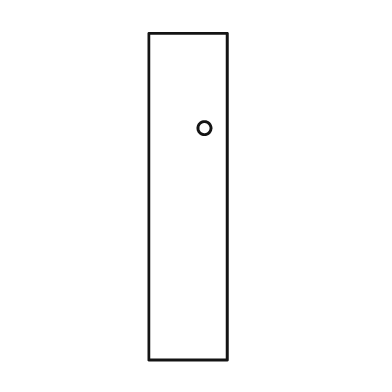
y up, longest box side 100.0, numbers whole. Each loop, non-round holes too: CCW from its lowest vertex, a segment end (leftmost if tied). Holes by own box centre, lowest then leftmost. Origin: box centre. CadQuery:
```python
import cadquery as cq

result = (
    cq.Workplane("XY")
    .moveTo(-12.0, -50.0)
    .lineTo(12.0, -50.0)
    .lineTo(12.0, 50.0)
    .lineTo(-12.0, 50.0)
    .close()
    .moveTo(5.0, 21.0)
    .circle(2.0)
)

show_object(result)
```